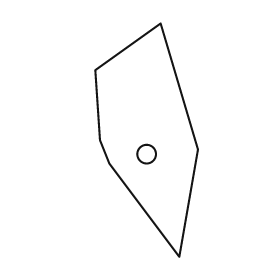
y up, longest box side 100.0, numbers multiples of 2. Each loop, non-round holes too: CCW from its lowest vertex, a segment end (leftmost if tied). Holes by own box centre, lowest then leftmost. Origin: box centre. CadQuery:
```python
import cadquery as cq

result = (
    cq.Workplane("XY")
    .moveTo(14.0, -50.0)
    .lineTo(22.0, -4.0)
    .lineTo(6.0, 50.0)
    .lineTo(-22.0, 30.0)
    .lineTo(-20.0, 0.0)
    .lineTo(-16.0, -10.0)
    .close()
    .moveTo(0.0, -6.0)
    .circle(4.0)
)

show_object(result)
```